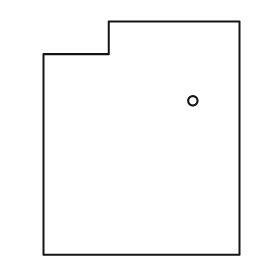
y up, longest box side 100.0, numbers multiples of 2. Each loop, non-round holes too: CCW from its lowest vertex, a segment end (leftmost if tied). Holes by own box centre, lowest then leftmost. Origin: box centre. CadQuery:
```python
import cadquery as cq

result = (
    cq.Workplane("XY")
    .moveTo(-42.0, -50.0)
    .lineTo(42.0, -50.0)
    .lineTo(42.0, 50.0)
    .lineTo(-14.0, 50.0)
    .lineTo(-14.0, 36.0)
    .lineTo(-42.0, 36.0)
    .close()
    .moveTo(22.0, 16.0)
    .circle(2.0)
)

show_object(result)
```